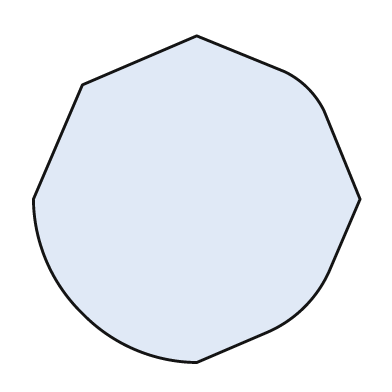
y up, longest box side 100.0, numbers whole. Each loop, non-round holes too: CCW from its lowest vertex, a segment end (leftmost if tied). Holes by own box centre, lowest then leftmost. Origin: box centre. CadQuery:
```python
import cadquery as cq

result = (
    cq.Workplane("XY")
    .moveTo(0.0, -50.0)
    .lineTo(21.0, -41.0)
    .threePointArc((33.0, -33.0), (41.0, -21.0))
    .lineTo(50.0, 0.0)
    .lineTo(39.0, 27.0)
    .threePointArc((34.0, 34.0), (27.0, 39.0))
    .lineTo(0.0, 50.0)
    .lineTo(-35.0, 35.0)
    .lineTo(-50.0, 0.0)
    .threePointArc((-46.0, -19.0), (-35.0, -35.0))
    .threePointArc((-19.0, -46.0), (0.0, -50.0))
    .close()
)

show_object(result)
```